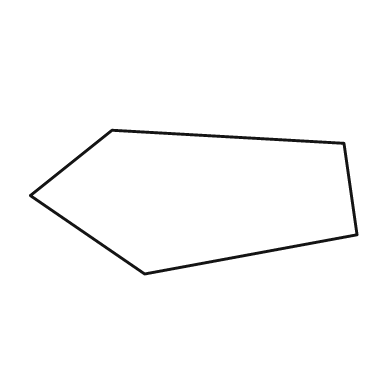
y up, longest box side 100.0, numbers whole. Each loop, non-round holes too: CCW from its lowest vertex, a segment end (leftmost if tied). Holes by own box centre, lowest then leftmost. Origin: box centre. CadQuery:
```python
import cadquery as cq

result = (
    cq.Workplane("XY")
    .moveTo(-15.0, -22.0)
    .lineTo(50.0, -10.0)
    .lineTo(46.0, 18.0)
    .lineTo(-25.0, 22.0)
    .lineTo(-50.0, 2.0)
    .close()
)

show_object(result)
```